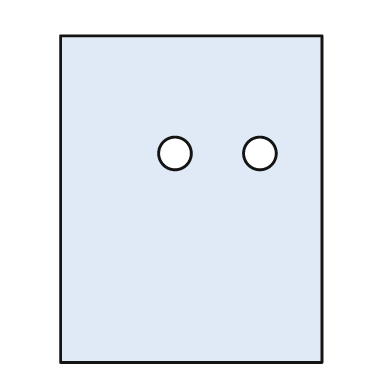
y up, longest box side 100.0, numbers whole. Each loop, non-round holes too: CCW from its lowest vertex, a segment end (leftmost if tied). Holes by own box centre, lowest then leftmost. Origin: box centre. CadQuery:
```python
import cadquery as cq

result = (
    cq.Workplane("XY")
    .moveTo(-40.0, -50.0)
    .lineTo(40.0, -50.0)
    .lineTo(40.0, 50.0)
    .lineTo(-40.0, 50.0)
    .close()
    .moveTo(-5.0, 14.0)
    .circle(5.0)
    .moveTo(21.0, 14.0)
    .circle(5.0)
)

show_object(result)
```